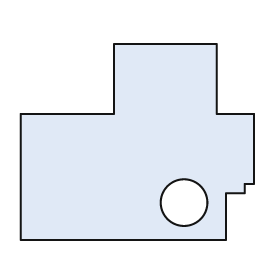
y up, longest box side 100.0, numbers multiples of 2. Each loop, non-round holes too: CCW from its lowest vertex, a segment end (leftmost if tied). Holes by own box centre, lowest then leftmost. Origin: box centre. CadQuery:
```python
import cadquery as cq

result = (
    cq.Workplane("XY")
    .moveTo(-50.0, -42.0)
    .lineTo(38.0, -42.0)
    .lineTo(38.0, -22.0)
    .lineTo(46.0, -22.0)
    .lineTo(46.0, -18.0)
    .lineTo(50.0, -18.0)
    .lineTo(50.0, 12.0)
    .lineTo(34.0, 12.0)
    .lineTo(34.0, 42.0)
    .lineTo(-10.0, 42.0)
    .lineTo(-10.0, 12.0)
    .lineTo(-50.0, 12.0)
    .close()
    .moveTo(20.0, -26.0)
    .circle(10.0)
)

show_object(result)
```